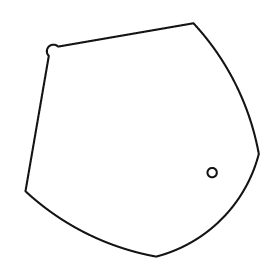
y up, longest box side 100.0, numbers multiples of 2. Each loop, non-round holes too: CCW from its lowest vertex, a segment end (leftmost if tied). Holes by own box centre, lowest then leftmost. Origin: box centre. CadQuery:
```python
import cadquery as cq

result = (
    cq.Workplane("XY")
    .moveTo(6.0, -50.0)
    .threePointArc((34.0, -34.0), (50.0, -6.0))
    .threePointArc((40.0, 24.0), (22.0, 50.0))
    .lineTo(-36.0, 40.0)
    .threePointArc((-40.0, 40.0), (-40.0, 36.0))
    .lineTo(-50.0, -22.0)
    .threePointArc((-24.0, -40.0), (6.0, -50.0))
    .close()
    .moveTo(30.0, -14.0)
    .circle(2.0)
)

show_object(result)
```